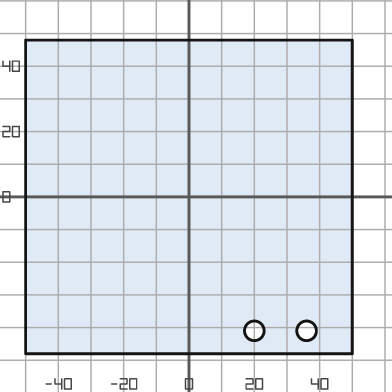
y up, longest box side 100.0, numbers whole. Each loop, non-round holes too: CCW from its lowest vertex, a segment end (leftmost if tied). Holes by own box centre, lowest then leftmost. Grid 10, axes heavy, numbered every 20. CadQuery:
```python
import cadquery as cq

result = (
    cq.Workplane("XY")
    .moveTo(-50.0, -48.0)
    .lineTo(50.0, -48.0)
    .lineTo(50.0, 48.0)
    .lineTo(-50.0, 48.0)
    .close()
    .moveTo(20.0, -41.0)
    .circle(3.0)
    .moveTo(36.0, -41.0)
    .circle(3.0)
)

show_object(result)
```